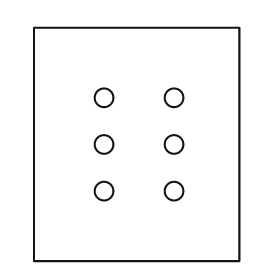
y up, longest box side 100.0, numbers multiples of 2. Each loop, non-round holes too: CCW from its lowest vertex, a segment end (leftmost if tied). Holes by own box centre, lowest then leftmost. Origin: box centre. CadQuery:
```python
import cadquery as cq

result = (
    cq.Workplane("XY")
    .moveTo(-44.0, -50.0)
    .lineTo(44.0, -50.0)
    .lineTo(44.0, 50.0)
    .lineTo(-44.0, 50.0)
    .close()
    .moveTo(-14.0, -20.0)
    .circle(4.0)
    .moveTo(16.0, -20.0)
    .circle(4.0)
    .moveTo(-14.0, 0.0)
    .circle(4.0)
    .moveTo(16.0, 0.0)
    .circle(4.0)
    .moveTo(-14.0, 20.0)
    .circle(4.0)
    .moveTo(16.0, 20.0)
    .circle(4.0)
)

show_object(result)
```